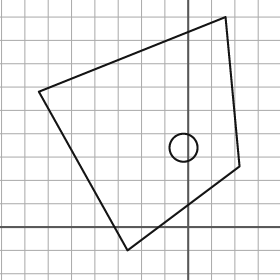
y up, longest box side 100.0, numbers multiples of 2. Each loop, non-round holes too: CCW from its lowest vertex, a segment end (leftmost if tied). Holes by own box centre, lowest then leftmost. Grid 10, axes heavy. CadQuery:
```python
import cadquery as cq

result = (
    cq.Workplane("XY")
    .moveTo(-26.0, -10.0)
    .lineTo(22.0, 26.0)
    .lineTo(16.0, 90.0)
    .lineTo(-64.0, 58.0)
    .close()
    .moveTo(-2.0, 34.0)
    .circle(6.0)
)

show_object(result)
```